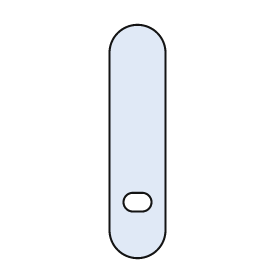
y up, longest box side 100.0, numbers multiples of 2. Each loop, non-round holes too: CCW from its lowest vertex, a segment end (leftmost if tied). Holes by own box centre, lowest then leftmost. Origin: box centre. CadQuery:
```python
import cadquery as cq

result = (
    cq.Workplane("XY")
    .moveTo(-12.0, -38.0)
    .threePointArc((0.0, -50.0), (12.0, -38.0))
    .lineTo(12.0, 38.0)
    .threePointArc((0.0, 50.0), (-12.0, 38.0))
    .close()
    .moveTo(-2.0, -30.0)
    .lineTo(2.0, -30.0)
    .threePointArc((6.0, -26.0), (2.0, -22.0))
    .lineTo(-2.0, -22.0)
    .threePointArc((-6.0, -26.0), (-2.0, -30.0))
    .close()
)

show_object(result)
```